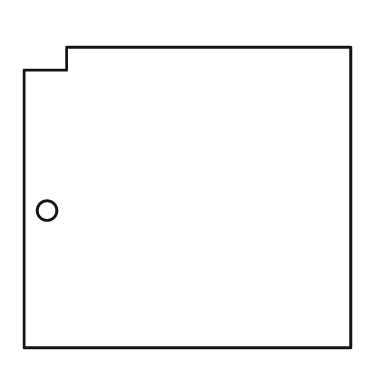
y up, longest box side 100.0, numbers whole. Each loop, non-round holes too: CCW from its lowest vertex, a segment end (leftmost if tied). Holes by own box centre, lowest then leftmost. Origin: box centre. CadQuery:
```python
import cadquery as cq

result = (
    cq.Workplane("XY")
    .moveTo(-50.0, -46.0)
    .lineTo(50.0, -46.0)
    .lineTo(50.0, 46.0)
    .lineTo(-37.0, 46.0)
    .lineTo(-37.0, 39.0)
    .lineTo(-50.0, 39.0)
    .close()
    .moveTo(-43.0, -4.0)
    .circle(3.0)
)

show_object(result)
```